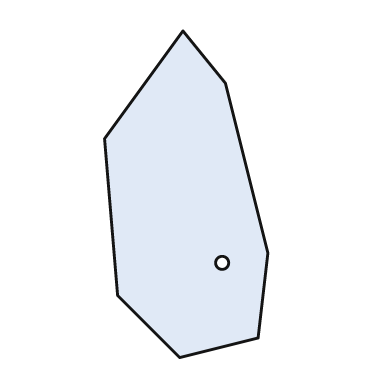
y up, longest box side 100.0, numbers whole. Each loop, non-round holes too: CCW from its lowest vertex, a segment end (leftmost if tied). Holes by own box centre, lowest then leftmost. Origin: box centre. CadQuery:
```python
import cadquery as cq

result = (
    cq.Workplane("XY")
    .moveTo(-2.0, -50.0)
    .lineTo(22.0, -44.0)
    .lineTo(25.0, -18.0)
    .lineTo(12.0, 34.0)
    .lineTo(-1.0, 50.0)
    .lineTo(-25.0, 17.0)
    .lineTo(-21.0, -31.0)
    .close()
    .moveTo(11.0, -21.0)
    .circle(2.0)
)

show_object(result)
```